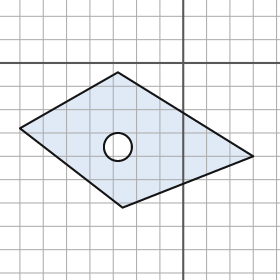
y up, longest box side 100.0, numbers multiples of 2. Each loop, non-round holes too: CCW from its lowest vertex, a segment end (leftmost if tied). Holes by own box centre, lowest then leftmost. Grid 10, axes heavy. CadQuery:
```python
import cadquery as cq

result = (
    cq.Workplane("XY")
    .moveTo(-26.0, -62.0)
    .lineTo(30.0, -40.0)
    .lineTo(-28.0, -4.0)
    .lineTo(-70.0, -28.0)
    .close()
    .moveTo(-28.0, -36.0)
    .circle(6.0)
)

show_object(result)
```